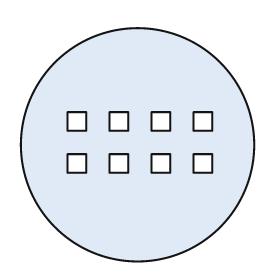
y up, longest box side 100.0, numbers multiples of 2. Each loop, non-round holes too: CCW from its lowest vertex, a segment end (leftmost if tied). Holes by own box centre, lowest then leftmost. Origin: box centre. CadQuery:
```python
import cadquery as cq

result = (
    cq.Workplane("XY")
    .moveTo(0.0, 0.0)
    .circle(50.0)
    .moveTo(-30.0, -12.0)
    .lineTo(-22.0, -12.0)
    .lineTo(-22.0, -4.0)
    .lineTo(-30.0, -4.0)
    .close()
    .moveTo(-12.0, -12.0)
    .lineTo(-4.0, -12.0)
    .lineTo(-4.0, -4.0)
    .lineTo(-12.0, -4.0)
    .close()
    .moveTo(6.0, -12.0)
    .lineTo(14.0, -12.0)
    .lineTo(14.0, -4.0)
    .lineTo(6.0, -4.0)
    .close()
    .moveTo(24.0, -12.0)
    .lineTo(32.0, -12.0)
    .lineTo(32.0, -4.0)
    .lineTo(24.0, -4.0)
    .close()
    .moveTo(-30.0, 6.0)
    .lineTo(-22.0, 6.0)
    .lineTo(-22.0, 14.0)
    .lineTo(-30.0, 14.0)
    .close()
    .moveTo(-12.0, 6.0)
    .lineTo(-4.0, 6.0)
    .lineTo(-4.0, 14.0)
    .lineTo(-12.0, 14.0)
    .close()
    .moveTo(6.0, 6.0)
    .lineTo(14.0, 6.0)
    .lineTo(14.0, 14.0)
    .lineTo(6.0, 14.0)
    .close()
    .moveTo(24.0, 6.0)
    .lineTo(32.0, 6.0)
    .lineTo(32.0, 14.0)
    .lineTo(24.0, 14.0)
    .close()
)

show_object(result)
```